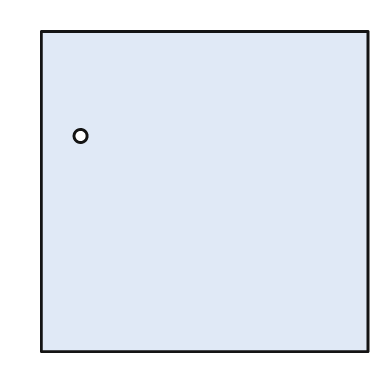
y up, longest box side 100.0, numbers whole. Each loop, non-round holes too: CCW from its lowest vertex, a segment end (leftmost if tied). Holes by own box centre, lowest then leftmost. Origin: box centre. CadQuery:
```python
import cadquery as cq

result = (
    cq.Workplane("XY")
    .moveTo(-50.0, -49.0)
    .lineTo(50.0, -49.0)
    .lineTo(50.0, 49.0)
    .lineTo(-50.0, 49.0)
    .close()
    .moveTo(-38.0, 17.0)
    .circle(2.0)
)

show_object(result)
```